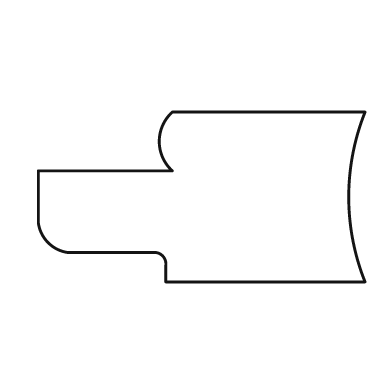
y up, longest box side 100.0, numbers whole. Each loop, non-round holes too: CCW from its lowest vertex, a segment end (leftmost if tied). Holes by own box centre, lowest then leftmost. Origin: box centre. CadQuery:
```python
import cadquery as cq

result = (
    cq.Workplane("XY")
    .moveTo(-11.0, -26.0)
    .lineTo(50.0, -26.0)
    .threePointArc((45.0, 0.0), (50.0, 26.0))
    .lineTo(-9.0, 26.0)
    .threePointArc((-13.0, 17.0), (-9.0, 8.0))
    .lineTo(-50.0, 8.0)
    .lineTo(-50.0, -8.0)
    .threePointArc((-47.0, -14.0), (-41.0, -17.0))
    .lineTo(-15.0, -17.0)
    .threePointArc((-12.0, -18.0), (-11.0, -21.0))
    .close()
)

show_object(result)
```